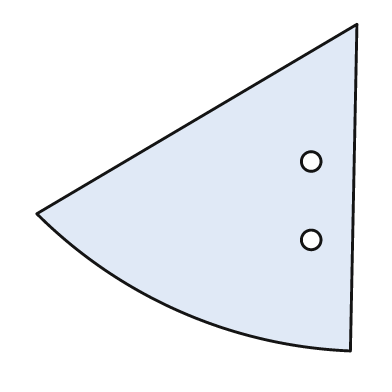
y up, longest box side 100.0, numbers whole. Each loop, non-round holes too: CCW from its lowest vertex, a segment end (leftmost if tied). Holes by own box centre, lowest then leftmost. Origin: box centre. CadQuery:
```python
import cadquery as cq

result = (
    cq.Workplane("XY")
    .moveTo(47.0, -50.0)
    .lineTo(49.0, 50.0)
    .lineTo(-49.0, -8.0)
    .threePointArc((-5.0, -38.0), (47.0, -50.0))
    .close()
    .moveTo(35.0, -16.0)
    .circle(3.0)
    .moveTo(35.0, 8.0)
    .circle(3.0)
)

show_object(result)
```